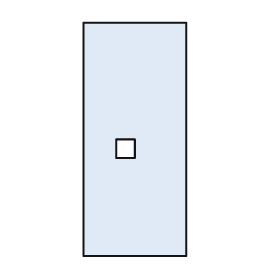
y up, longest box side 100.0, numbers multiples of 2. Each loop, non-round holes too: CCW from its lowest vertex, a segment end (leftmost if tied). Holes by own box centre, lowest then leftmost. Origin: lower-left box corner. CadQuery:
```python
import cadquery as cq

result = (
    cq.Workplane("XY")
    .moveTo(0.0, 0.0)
    .lineTo(44.0, 0.0)
    .lineTo(44.0, 100.0)
    .lineTo(0.0, 100.0)
    .close()
    .moveTo(14.0, 42.0)
    .lineTo(22.0, 42.0)
    .lineTo(22.0, 50.0)
    .lineTo(14.0, 50.0)
    .close()
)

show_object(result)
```